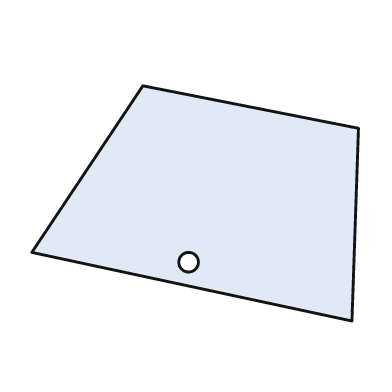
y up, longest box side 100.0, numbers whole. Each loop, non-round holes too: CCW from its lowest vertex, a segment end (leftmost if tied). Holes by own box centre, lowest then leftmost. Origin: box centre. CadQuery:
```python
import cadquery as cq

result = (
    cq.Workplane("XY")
    .moveTo(48.0, -36.0)
    .lineTo(50.0, 23.0)
    .lineTo(-16.0, 36.0)
    .lineTo(-50.0, -15.0)
    .close()
    .moveTo(-2.0, -18.0)
    .circle(3.0)
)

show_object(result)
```